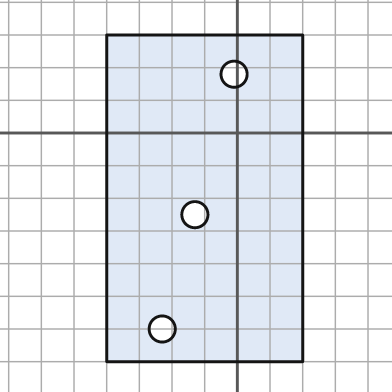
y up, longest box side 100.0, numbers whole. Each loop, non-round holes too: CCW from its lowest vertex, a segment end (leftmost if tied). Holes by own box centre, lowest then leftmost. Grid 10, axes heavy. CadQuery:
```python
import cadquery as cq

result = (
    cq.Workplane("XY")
    .moveTo(-40.0, -70.0)
    .lineTo(20.0, -70.0)
    .lineTo(20.0, 30.0)
    .lineTo(-40.0, 30.0)
    .close()
    .moveTo(-23.0, -60.0)
    .circle(4.0)
    .moveTo(-13.0, -25.0)
    .circle(4.0)
    .moveTo(-1.0, 18.0)
    .circle(4.0)
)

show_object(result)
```